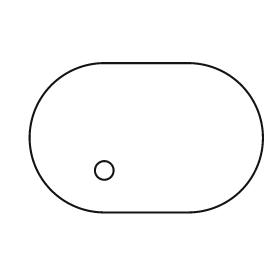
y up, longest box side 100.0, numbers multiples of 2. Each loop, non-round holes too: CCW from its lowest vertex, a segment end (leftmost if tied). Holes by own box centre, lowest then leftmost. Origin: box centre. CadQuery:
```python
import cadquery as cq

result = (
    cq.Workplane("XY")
    .moveTo(-18.0, -32.0)
    .lineTo(18.0, -32.0)
    .threePointArc((50.0, 0.0), (18.0, 32.0))
    .lineTo(-18.0, 32.0)
    .threePointArc((-50.0, 0.0), (-18.0, -32.0))
    .close()
    .moveTo(-18.0, -14.0)
    .circle(4.0)
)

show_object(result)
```